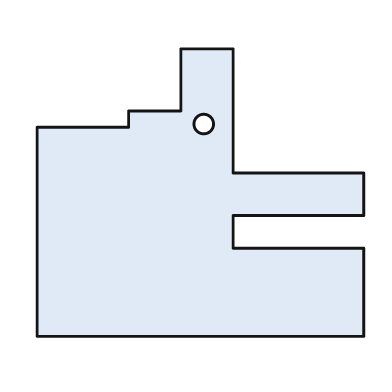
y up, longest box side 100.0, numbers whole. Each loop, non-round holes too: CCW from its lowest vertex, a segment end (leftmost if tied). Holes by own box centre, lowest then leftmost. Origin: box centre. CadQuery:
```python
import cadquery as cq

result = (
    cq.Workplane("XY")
    .moveTo(-50.0, -44.0)
    .lineTo(50.0, -44.0)
    .lineTo(50.0, -17.0)
    .lineTo(10.0, -17.0)
    .lineTo(10.0, -7.0)
    .lineTo(50.0, -7.0)
    .lineTo(50.0, 6.0)
    .lineTo(10.0, 6.0)
    .lineTo(10.0, 44.0)
    .lineTo(-6.0, 44.0)
    .lineTo(-6.0, 25.0)
    .lineTo(-22.0, 25.0)
    .lineTo(-22.0, 20.0)
    .lineTo(-50.0, 20.0)
    .close()
    .moveTo(1.0, 21.0)
    .circle(3.0)
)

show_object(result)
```